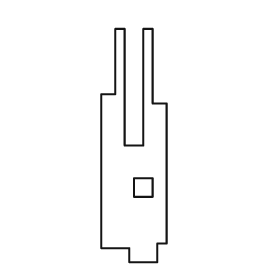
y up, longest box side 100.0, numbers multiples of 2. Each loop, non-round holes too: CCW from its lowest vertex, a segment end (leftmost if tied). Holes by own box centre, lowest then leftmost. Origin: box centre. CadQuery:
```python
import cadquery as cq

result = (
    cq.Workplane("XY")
    .moveTo(-2.0, -50.0)
    .lineTo(10.0, -50.0)
    .lineTo(10.0, -42.0)
    .lineTo(14.0, -42.0)
    .lineTo(14.0, 18.0)
    .lineTo(8.0, 18.0)
    .lineTo(8.0, 50.0)
    .lineTo(4.0, 50.0)
    .lineTo(4.0, 0.0)
    .lineTo(-4.0, 0.0)
    .lineTo(-4.0, 50.0)
    .lineTo(-8.0, 50.0)
    .lineTo(-8.0, 22.0)
    .lineTo(-14.0, 22.0)
    .lineTo(-14.0, -44.0)
    .lineTo(-2.0, -44.0)
    .close()
    .moveTo(0.0, -22.0)
    .lineTo(8.0, -22.0)
    .lineTo(8.0, -14.0)
    .lineTo(0.0, -14.0)
    .close()
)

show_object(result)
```